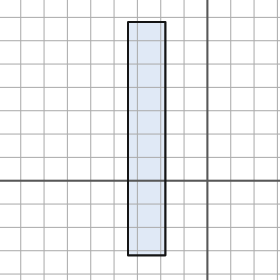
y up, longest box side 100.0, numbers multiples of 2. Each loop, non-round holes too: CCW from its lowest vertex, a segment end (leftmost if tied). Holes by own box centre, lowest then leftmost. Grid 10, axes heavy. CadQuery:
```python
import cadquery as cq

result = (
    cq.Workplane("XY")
    .moveTo(-34.0, -32.0)
    .lineTo(-18.0, -32.0)
    .lineTo(-18.0, 68.0)
    .lineTo(-34.0, 68.0)
    .close()
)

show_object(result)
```